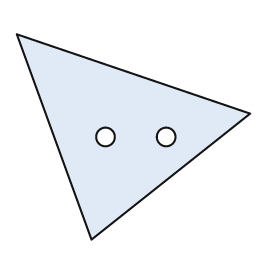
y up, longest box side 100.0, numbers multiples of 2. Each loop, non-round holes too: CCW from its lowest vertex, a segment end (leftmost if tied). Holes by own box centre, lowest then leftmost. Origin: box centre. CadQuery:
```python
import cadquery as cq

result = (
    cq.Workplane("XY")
    .moveTo(-18.0, -44.0)
    .lineTo(50.0, 10.0)
    .lineTo(-50.0, 44.0)
    .close()
    .moveTo(-12.0, 0.0)
    .circle(4.0)
    .moveTo(14.0, 0.0)
    .circle(4.0)
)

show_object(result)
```